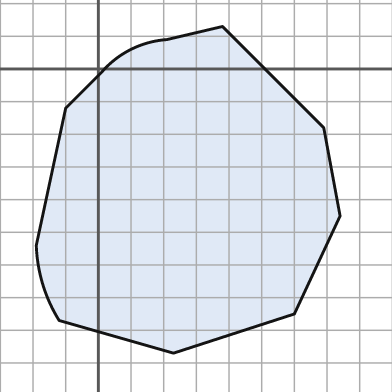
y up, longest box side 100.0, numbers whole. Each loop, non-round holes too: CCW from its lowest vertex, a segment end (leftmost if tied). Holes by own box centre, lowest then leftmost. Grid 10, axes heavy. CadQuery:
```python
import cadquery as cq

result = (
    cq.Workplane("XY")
    .moveTo(23.0, -87.0)
    .lineTo(60.0, -75.0)
    .lineTo(74.0, -45.0)
    .lineTo(69.0, -18.0)
    .lineTo(38.0, 13.0)
    .lineTo(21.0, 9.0)
    .threePointArc((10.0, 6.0), (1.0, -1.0))
    .lineTo(-10.0, -12.0)
    .lineTo(-19.0, -54.0)
    .threePointArc((-17.0, -66.0), (-12.0, -77.0))
    .close()
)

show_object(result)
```